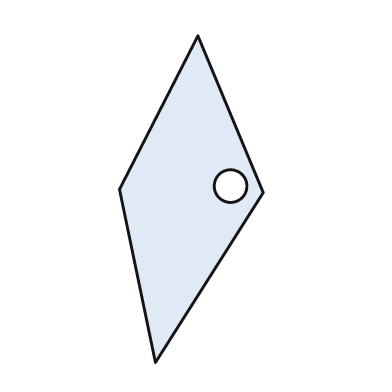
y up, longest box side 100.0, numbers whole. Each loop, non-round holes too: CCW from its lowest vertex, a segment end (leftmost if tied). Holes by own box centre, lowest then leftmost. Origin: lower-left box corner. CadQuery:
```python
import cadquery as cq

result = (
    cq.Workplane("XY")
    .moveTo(11.0, 0.0)
    .lineTo(44.0, 52.0)
    .lineTo(24.0, 100.0)
    .lineTo(0.0, 53.0)
    .close()
    .moveTo(34.0, 54.0)
    .circle(5.0)
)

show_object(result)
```